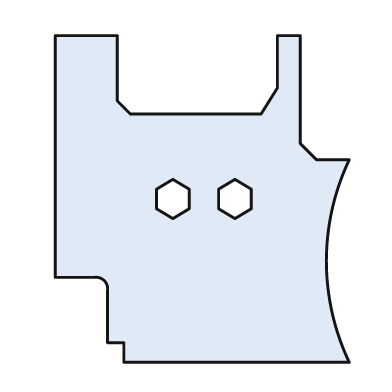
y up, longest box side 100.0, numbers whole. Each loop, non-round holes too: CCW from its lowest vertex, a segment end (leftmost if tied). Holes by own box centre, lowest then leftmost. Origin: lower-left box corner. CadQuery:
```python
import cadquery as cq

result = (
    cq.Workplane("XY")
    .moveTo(21.0, 0.0)
    .lineTo(90.0, 0.0)
    .threePointArc((83.0, 31.0), (90.0, 62.0))
    .lineTo(80.0, 62.0)
    .lineTo(75.0, 67.0)
    .lineTo(75.0, 100.0)
    .lineTo(68.0, 100.0)
    .lineTo(68.0, 84.0)
    .lineTo(63.0, 76.0)
    .lineTo(23.0, 76.0)
    .lineTo(19.0, 80.0)
    .lineTo(19.0, 100.0)
    .lineTo(0.0, 100.0)
    .lineTo(0.0, 26.0)
    .lineTo(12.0, 26.0)
    .threePointArc((15.0, 25.0), (16.0, 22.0))
    .lineTo(16.0, 6.0)
    .lineTo(21.0, 6.0)
    .close()
    .moveTo(36.0, 44.0)
    .lineTo(41.0, 47.0)
    .lineTo(41.0, 53.0)
    .lineTo(36.0, 56.0)
    .lineTo(31.0, 53.0)
    .lineTo(31.0, 47.0)
    .close()
    .moveTo(55.0, 44.0)
    .lineTo(60.0, 47.0)
    .lineTo(60.0, 53.0)
    .lineTo(55.0, 56.0)
    .lineTo(50.0, 53.0)
    .lineTo(50.0, 47.0)
    .close()
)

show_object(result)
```